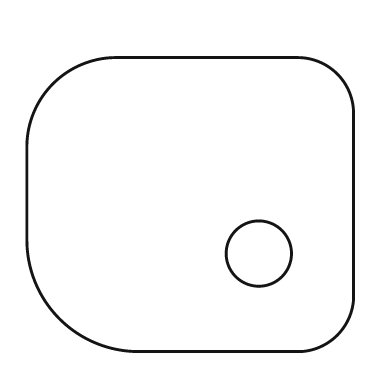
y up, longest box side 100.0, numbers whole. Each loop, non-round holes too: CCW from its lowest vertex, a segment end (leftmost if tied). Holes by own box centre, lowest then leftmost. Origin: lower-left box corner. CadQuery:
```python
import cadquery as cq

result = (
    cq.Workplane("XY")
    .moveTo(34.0, 0.0)
    .lineTo(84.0, 0.0)
    .threePointArc((95.0, 5.0), (100.0, 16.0))
    .lineTo(100.0, 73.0)
    .threePointArc((95.0, 85.0), (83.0, 90.0))
    .lineTo(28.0, 90.0)
    .threePointArc((8.0, 82.0), (0.0, 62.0))
    .lineTo(0.0, 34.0)
    .threePointArc((10.0, 10.0), (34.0, 0.0))
    .close()
    .moveTo(71.0, 30.0)
    .circle(10.0)
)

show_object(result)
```